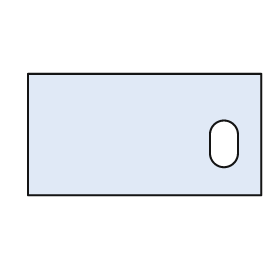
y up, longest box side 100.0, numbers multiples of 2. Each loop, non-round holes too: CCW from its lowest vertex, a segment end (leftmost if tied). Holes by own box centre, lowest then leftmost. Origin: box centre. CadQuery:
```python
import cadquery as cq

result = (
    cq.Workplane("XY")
    .moveTo(-50.0, -26.0)
    .lineTo(50.0, -26.0)
    .lineTo(50.0, 26.0)
    .lineTo(-50.0, 26.0)
    .close()
    .moveTo(28.0, -8.0)
    .threePointArc((34.0, -14.0), (40.0, -8.0))
    .lineTo(40.0, 0.0)
    .threePointArc((34.0, 6.0), (28.0, 0.0))
    .close()
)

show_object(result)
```